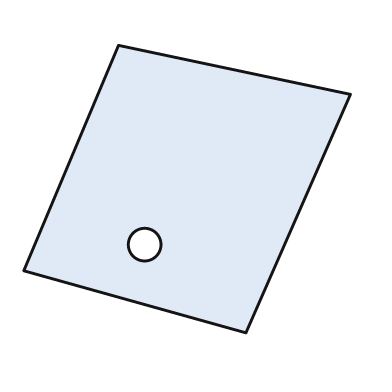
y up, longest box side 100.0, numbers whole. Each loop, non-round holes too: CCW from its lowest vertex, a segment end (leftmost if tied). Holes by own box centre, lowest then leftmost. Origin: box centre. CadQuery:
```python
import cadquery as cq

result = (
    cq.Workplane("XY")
    .moveTo(18.0, -44.0)
    .lineTo(50.0, 29.0)
    .lineTo(-21.0, 44.0)
    .lineTo(-50.0, -25.0)
    .close()
    .moveTo(-13.0, -17.0)
    .circle(5.0)
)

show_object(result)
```